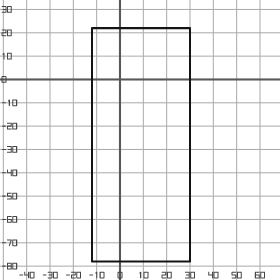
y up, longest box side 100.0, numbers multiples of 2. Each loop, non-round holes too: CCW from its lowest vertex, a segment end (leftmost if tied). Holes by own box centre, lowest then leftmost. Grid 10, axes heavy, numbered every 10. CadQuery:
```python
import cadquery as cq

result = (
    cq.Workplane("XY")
    .moveTo(-12.0, -78.0)
    .lineTo(30.0, -78.0)
    .lineTo(30.0, 22.0)
    .lineTo(-12.0, 22.0)
    .close()
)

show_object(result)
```